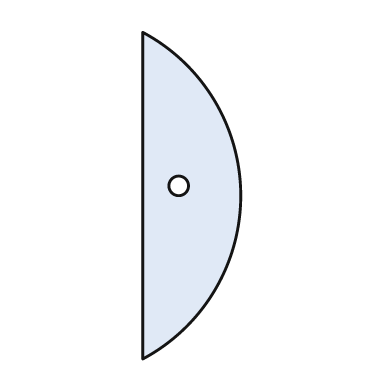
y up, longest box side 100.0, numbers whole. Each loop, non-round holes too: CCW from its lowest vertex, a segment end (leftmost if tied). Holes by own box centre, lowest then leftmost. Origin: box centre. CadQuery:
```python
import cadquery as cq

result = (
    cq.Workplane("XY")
    .moveTo(-15.0, -50.0)
    .threePointArc((15.0, 0.0), (-15.0, 50.0))
    .close()
    .moveTo(-4.0, 3.0)
    .circle(3.0)
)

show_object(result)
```